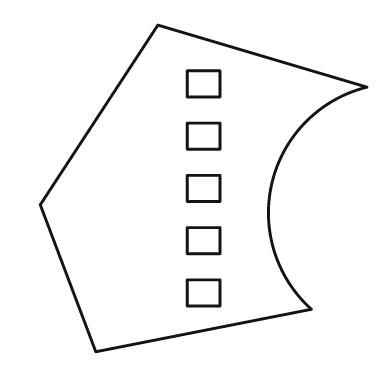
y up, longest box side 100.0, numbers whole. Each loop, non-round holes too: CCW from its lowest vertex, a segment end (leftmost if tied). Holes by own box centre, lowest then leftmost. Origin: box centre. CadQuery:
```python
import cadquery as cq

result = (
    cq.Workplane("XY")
    .moveTo(-33.0, -50.0)
    .lineTo(33.0, -37.0)
    .threePointArc((21.0, 2.0), (50.0, 31.0))
    .lineTo(-14.0, 50.0)
    .lineTo(-50.0, -5.0)
    .close()
    .moveTo(-5.0, -36.0)
    .lineTo(5.0, -36.0)
    .lineTo(5.0, -28.0)
    .lineTo(-5.0, -28.0)
    .close()
    .moveTo(-5.0, -20.0)
    .lineTo(5.0, -20.0)
    .lineTo(5.0, -12.0)
    .lineTo(-5.0, -12.0)
    .close()
    .moveTo(-5.0, -4.0)
    .lineTo(5.0, -4.0)
    .lineTo(5.0, 4.0)
    .lineTo(-5.0, 4.0)
    .close()
    .moveTo(-5.0, 12.0)
    .lineTo(5.0, 12.0)
    .lineTo(5.0, 20.0)
    .lineTo(-5.0, 20.0)
    .close()
    .moveTo(-5.0, 28.0)
    .lineTo(5.0, 28.0)
    .lineTo(5.0, 36.0)
    .lineTo(-5.0, 36.0)
    .close()
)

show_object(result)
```